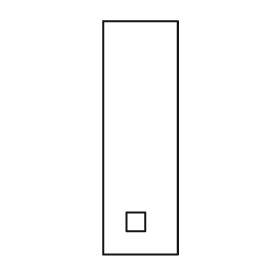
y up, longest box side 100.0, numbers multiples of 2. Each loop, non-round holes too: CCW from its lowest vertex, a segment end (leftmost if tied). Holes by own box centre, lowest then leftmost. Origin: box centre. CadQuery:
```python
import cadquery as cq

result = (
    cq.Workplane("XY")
    .moveTo(-16.0, -50.0)
    .lineTo(16.0, -50.0)
    .lineTo(16.0, 50.0)
    .lineTo(-16.0, 50.0)
    .close()
    .moveTo(-6.0, -40.0)
    .lineTo(2.0, -40.0)
    .lineTo(2.0, -32.0)
    .lineTo(-6.0, -32.0)
    .close()
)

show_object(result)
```